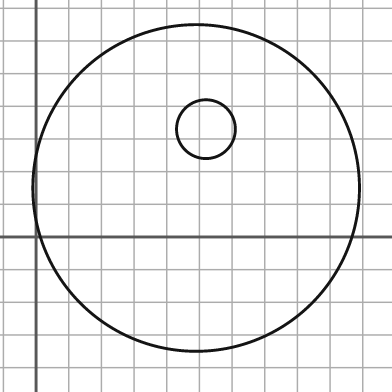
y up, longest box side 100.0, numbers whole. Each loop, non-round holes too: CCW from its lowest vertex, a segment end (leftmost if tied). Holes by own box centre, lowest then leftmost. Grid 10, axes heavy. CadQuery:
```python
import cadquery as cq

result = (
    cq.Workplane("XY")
    .moveTo(49.0, 15.0)
    .circle(50.0)
    .moveTo(52.0, 33.0)
    .circle(9.0)
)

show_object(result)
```